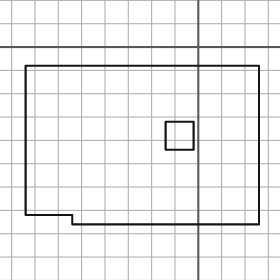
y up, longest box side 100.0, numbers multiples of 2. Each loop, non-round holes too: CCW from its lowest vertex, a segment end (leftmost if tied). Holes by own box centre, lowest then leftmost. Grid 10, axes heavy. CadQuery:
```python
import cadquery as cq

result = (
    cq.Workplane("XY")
    .moveTo(-54.0, -76.0)
    .lineTo(26.0, -76.0)
    .lineTo(26.0, -8.0)
    .lineTo(-74.0, -8.0)
    .lineTo(-74.0, -72.0)
    .lineTo(-54.0, -72.0)
    .close()
    .moveTo(-14.0, -44.0)
    .lineTo(-2.0, -44.0)
    .lineTo(-2.0, -32.0)
    .lineTo(-14.0, -32.0)
    .close()
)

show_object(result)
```